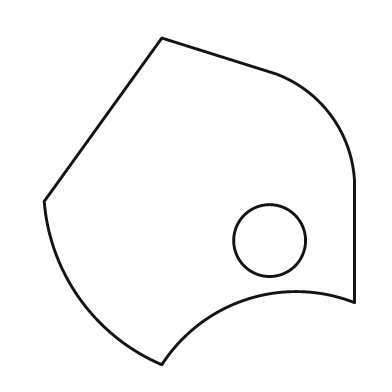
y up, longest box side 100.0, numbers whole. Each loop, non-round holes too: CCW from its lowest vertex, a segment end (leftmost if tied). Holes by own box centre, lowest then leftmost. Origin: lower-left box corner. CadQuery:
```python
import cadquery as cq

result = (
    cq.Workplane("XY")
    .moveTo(36.0, 0.0)
    .threePointArc((62.0, 20.0), (95.0, 19.0))
    .lineTo(95.0, 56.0)
    .threePointArc((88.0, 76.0), (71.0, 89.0))
    .lineTo(36.0, 100.0)
    .lineTo(0.0, 50.0)
    .threePointArc((11.0, 20.0), (36.0, 0.0))
    .close()
    .moveTo(69.0, 38.0)
    .circle(11.0)
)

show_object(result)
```